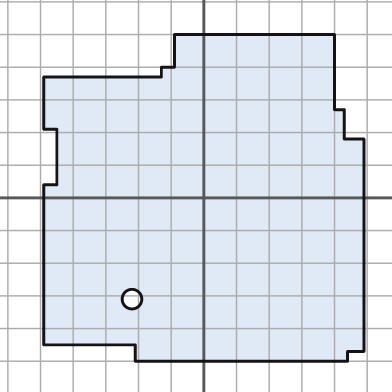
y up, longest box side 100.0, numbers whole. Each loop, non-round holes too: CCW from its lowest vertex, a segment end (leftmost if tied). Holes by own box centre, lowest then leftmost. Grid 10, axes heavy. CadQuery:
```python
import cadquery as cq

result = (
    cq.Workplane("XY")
    .moveTo(-21.0, -50.0)
    .lineTo(44.0, -50.0)
    .lineTo(44.0, -47.0)
    .lineTo(49.0, -47.0)
    .lineTo(49.0, 18.0)
    .lineTo(43.0, 18.0)
    .lineTo(43.0, 27.0)
    .lineTo(40.0, 27.0)
    .lineTo(40.0, 50.0)
    .lineTo(-9.0, 50.0)
    .lineTo(-9.0, 40.0)
    .lineTo(-13.0, 40.0)
    .lineTo(-13.0, 37.0)
    .lineTo(-49.0, 37.0)
    .lineTo(-49.0, 21.0)
    .lineTo(-45.0, 21.0)
    .lineTo(-45.0, 4.0)
    .lineTo(-49.0, 4.0)
    .lineTo(-49.0, -45.0)
    .lineTo(-21.0, -45.0)
    .close()
    .moveTo(-22.0, -31.0)
    .circle(3.0)
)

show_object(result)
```